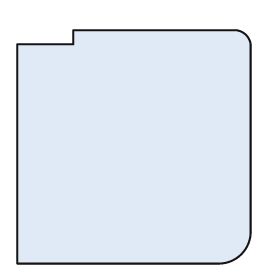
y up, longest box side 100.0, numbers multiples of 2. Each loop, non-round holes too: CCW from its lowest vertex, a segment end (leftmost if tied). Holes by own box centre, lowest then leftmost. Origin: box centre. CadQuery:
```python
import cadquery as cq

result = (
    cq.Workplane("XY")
    .moveTo(-50.0, -50.0)
    .lineTo(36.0, -50.0)
    .threePointArc((46.0, -46.0), (50.0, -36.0))
    .lineTo(50.0, 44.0)
    .threePointArc((48.0, 48.0), (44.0, 50.0))
    .lineTo(-26.0, 50.0)
    .lineTo(-26.0, 44.0)
    .lineTo(-50.0, 44.0)
    .close()
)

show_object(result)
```